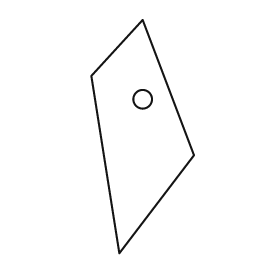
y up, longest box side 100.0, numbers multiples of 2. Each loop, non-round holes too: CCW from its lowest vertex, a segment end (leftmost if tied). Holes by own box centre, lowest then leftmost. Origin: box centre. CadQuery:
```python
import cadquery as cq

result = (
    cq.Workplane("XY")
    .moveTo(-10.0, -50.0)
    .lineTo(22.0, -8.0)
    .lineTo(0.0, 50.0)
    .lineTo(-22.0, 26.0)
    .close()
    .moveTo(0.0, 16.0)
    .circle(4.0)
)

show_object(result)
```